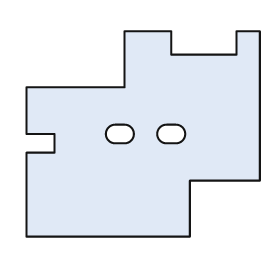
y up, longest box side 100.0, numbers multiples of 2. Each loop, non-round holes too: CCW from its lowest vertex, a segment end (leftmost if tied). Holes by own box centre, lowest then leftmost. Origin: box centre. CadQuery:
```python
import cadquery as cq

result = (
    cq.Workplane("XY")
    .moveTo(-50.0, -44.0)
    .lineTo(20.0, -44.0)
    .lineTo(20.0, -20.0)
    .lineTo(50.0, -20.0)
    .lineTo(50.0, 44.0)
    .lineTo(40.0, 44.0)
    .lineTo(40.0, 34.0)
    .lineTo(12.0, 34.0)
    .lineTo(12.0, 44.0)
    .lineTo(-8.0, 44.0)
    .lineTo(-8.0, 20.0)
    .lineTo(-50.0, 20.0)
    .lineTo(-50.0, 0.0)
    .lineTo(-38.0, 0.0)
    .lineTo(-38.0, -8.0)
    .lineTo(-50.0, -8.0)
    .close()
    .moveTo(-12.0, -4.0)
    .lineTo(-8.0, -4.0)
    .threePointArc((-4.0, 0.0), (-8.0, 4.0))
    .lineTo(-12.0, 4.0)
    .threePointArc((-16.0, 0.0), (-12.0, -4.0))
    .close()
    .moveTo(10.0, -4.0)
    .lineTo(14.0, -4.0)
    .threePointArc((18.0, 0.0), (14.0, 4.0))
    .lineTo(10.0, 4.0)
    .threePointArc((6.0, 0.0), (10.0, -4.0))
    .close()
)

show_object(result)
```